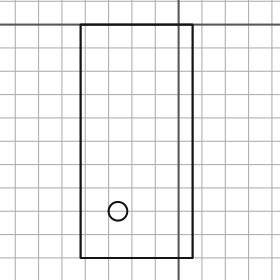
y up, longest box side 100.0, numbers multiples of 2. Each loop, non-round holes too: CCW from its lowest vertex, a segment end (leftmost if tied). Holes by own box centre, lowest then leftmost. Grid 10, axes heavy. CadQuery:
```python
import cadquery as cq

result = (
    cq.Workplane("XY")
    .moveTo(-42.0, -100.0)
    .lineTo(6.0, -100.0)
    .lineTo(6.0, 0.0)
    .lineTo(-42.0, 0.0)
    .close()
    .moveTo(-26.0, -80.0)
    .circle(4.0)
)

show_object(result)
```